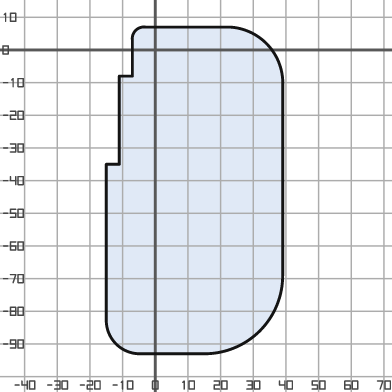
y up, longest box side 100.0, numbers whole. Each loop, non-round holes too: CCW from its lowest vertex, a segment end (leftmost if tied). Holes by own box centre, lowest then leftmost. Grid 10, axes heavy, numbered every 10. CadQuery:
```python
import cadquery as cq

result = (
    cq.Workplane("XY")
    .moveTo(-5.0, -93.0)
    .lineTo(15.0, -93.0)
    .threePointArc((32.0, -86.0), (39.0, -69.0))
    .lineTo(39.0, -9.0)
    .threePointArc((34.0, 2.0), (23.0, 7.0))
    .lineTo(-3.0, 7.0)
    .threePointArc((-6.0, 6.0), (-7.0, 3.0))
    .lineTo(-7.0, -8.0)
    .lineTo(-11.0, -8.0)
    .lineTo(-11.0, -35.0)
    .lineTo(-15.0, -35.0)
    .lineTo(-15.0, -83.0)
    .threePointArc((-12.0, -90.0), (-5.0, -93.0))
    .close()
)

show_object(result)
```